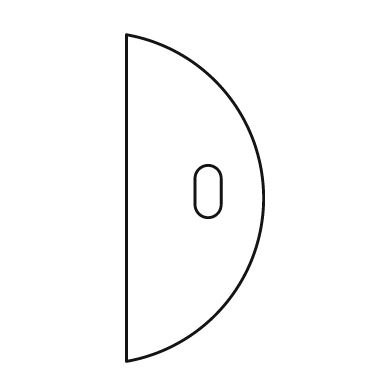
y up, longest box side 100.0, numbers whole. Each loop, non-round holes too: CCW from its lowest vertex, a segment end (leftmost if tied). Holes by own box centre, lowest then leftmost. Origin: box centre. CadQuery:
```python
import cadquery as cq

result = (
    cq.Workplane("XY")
    .moveTo(-21.0, -50.0)
    .threePointArc((21.0, 0.0), (-21.0, 50.0))
    .close()
    .moveTo(0.0, -2.0)
    .threePointArc((4.0, -6.0), (8.0, -2.0))
    .lineTo(8.0, 6.0)
    .threePointArc((4.0, 10.0), (0.0, 6.0))
    .close()
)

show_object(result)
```